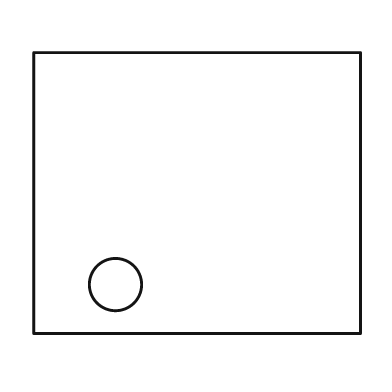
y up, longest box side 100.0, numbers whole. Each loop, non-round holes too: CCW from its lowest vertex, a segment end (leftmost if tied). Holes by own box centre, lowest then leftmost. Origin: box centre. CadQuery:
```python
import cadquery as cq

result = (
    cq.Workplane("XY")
    .moveTo(-50.0, -43.0)
    .lineTo(50.0, -43.0)
    .lineTo(50.0, 43.0)
    .lineTo(-50.0, 43.0)
    .close()
    .moveTo(-25.0, -28.0)
    .circle(8.0)
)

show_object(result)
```